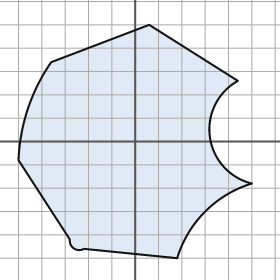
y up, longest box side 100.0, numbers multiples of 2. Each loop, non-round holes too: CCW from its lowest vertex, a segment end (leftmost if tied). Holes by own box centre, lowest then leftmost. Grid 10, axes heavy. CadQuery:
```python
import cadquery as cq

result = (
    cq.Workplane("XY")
    .moveTo(18.0, -50.0)
    .threePointArc((30.0, -30.0), (50.0, -18.0))
    .threePointArc((32.0, 2.0), (44.0, 26.0))
    .lineTo(6.0, 50.0)
    .lineTo(-36.0, 34.0)
    .threePointArc((-46.0, 14.0), (-50.0, -8.0))
    .lineTo(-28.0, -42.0)
    .threePointArc((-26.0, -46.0), (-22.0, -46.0))
    .close()
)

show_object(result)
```